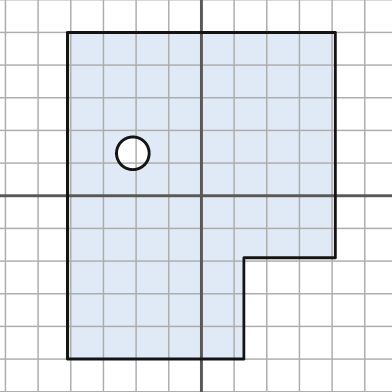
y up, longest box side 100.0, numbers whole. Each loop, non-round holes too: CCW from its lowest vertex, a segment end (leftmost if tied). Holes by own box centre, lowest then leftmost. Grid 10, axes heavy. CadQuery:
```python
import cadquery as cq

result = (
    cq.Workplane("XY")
    .moveTo(-41.0, -50.0)
    .lineTo(13.0, -50.0)
    .lineTo(13.0, -19.0)
    .lineTo(41.0, -19.0)
    .lineTo(41.0, 50.0)
    .lineTo(-41.0, 50.0)
    .close()
    .moveTo(-21.0, 13.0)
    .circle(5.0)
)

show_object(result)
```